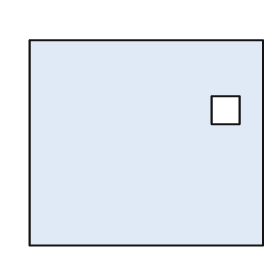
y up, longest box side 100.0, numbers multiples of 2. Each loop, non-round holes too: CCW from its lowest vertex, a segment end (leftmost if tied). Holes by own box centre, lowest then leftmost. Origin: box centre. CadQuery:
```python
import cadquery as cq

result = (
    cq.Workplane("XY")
    .moveTo(-50.0, -44.0)
    .lineTo(50.0, -44.0)
    .lineTo(50.0, 44.0)
    .lineTo(-50.0, 44.0)
    .close()
    .moveTo(28.0, 8.0)
    .lineTo(40.0, 8.0)
    .lineTo(40.0, 20.0)
    .lineTo(28.0, 20.0)
    .close()
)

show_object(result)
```